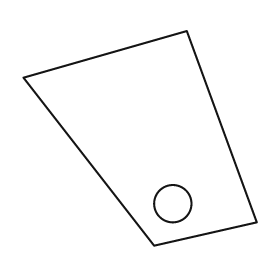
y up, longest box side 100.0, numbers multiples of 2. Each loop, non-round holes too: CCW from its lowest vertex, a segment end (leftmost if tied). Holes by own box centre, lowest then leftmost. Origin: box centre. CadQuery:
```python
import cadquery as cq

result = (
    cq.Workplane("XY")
    .moveTo(6.0, -46.0)
    .lineTo(50.0, -36.0)
    .lineTo(20.0, 46.0)
    .lineTo(-50.0, 26.0)
    .close()
    .moveTo(14.0, -28.0)
    .circle(8.0)
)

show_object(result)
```